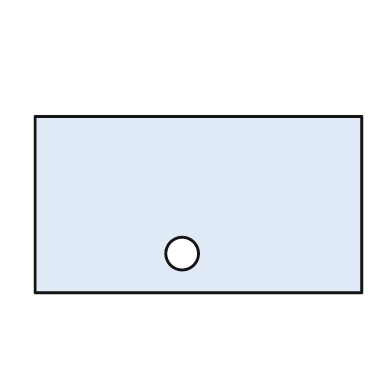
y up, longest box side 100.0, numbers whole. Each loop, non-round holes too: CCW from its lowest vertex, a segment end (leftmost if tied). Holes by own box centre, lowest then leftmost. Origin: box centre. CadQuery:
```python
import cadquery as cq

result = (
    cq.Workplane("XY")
    .moveTo(-50.0, -27.0)
    .lineTo(50.0, -27.0)
    .lineTo(50.0, 27.0)
    .lineTo(-50.0, 27.0)
    .close()
    .moveTo(-5.0, -15.0)
    .circle(5.0)
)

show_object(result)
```